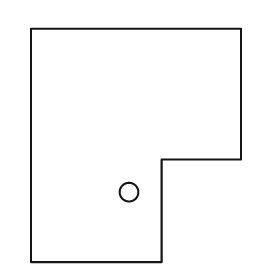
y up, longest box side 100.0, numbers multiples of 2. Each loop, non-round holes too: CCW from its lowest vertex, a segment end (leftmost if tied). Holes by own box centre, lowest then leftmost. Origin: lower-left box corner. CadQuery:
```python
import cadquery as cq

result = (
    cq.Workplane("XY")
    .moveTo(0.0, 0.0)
    .lineTo(56.0, 0.0)
    .lineTo(56.0, 44.0)
    .lineTo(90.0, 44.0)
    .lineTo(90.0, 100.0)
    .lineTo(0.0, 100.0)
    .close()
    .moveTo(42.0, 30.0)
    .circle(4.0)
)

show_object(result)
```